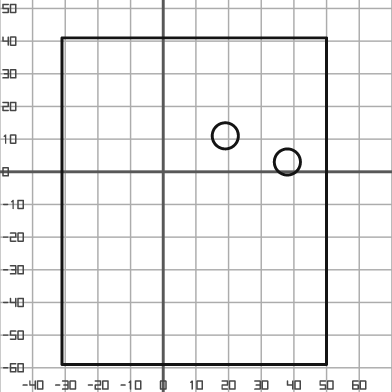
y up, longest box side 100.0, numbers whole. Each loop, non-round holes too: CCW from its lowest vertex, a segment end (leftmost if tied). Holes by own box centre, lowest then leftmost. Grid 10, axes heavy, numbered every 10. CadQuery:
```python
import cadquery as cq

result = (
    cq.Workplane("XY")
    .moveTo(-31.0, -59.0)
    .lineTo(50.0, -59.0)
    .lineTo(50.0, 41.0)
    .lineTo(-31.0, 41.0)
    .close()
    .moveTo(38.0, 3.0)
    .circle(4.0)
    .moveTo(19.0, 11.0)
    .circle(4.0)
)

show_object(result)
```